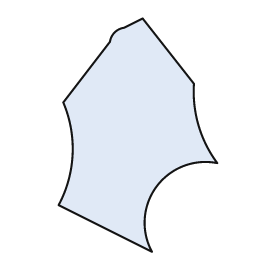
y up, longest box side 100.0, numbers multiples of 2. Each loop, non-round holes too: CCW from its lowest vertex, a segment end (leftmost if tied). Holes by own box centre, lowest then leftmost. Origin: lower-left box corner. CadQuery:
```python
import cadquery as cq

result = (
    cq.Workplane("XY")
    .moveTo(40.0, 0.0)
    .threePointArc((42.0, 28.0), (68.0, 38.0))
    .threePointArc((60.0, 54.0), (58.0, 72.0))
    .lineTo(36.0, 100.0)
    .lineTo(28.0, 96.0)
    .threePointArc((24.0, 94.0), (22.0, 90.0))
    .lineTo(2.0, 64.0)
    .threePointArc((6.0, 42.0), (0.0, 20.0))
    .close()
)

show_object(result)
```